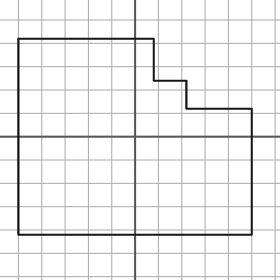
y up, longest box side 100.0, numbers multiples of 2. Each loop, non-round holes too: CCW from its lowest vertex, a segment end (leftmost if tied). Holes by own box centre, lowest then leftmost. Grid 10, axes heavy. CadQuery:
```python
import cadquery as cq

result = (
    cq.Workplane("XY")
    .moveTo(-50.0, -42.0)
    .lineTo(50.0, -42.0)
    .lineTo(50.0, 12.0)
    .lineTo(22.0, 12.0)
    .lineTo(22.0, 24.0)
    .lineTo(8.0, 24.0)
    .lineTo(8.0, 42.0)
    .lineTo(-50.0, 42.0)
    .close()
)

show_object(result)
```